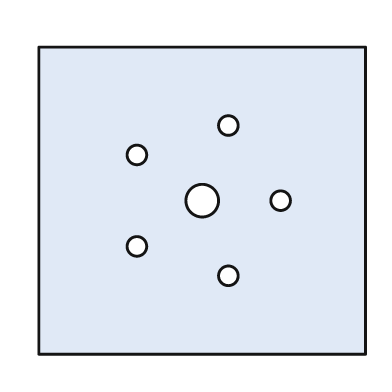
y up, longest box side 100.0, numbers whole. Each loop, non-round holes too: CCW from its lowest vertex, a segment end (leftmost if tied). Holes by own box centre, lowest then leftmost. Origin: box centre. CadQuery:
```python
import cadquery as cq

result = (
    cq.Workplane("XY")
    .moveTo(-50.0, -47.0)
    .lineTo(50.0, -47.0)
    .lineTo(50.0, 47.0)
    .lineTo(-50.0, 47.0)
    .close()
    .moveTo(8.0, -23.0)
    .circle(3.0)
    .moveTo(-20.0, -14.0)
    .circle(3.0)
    .moveTo(0.0, 0.0)
    .circle(5.0)
    .moveTo(24.0, 0.0)
    .circle(3.0)
    .moveTo(-20.0, 14.0)
    .circle(3.0)
    .moveTo(8.0, 23.0)
    .circle(3.0)
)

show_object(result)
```